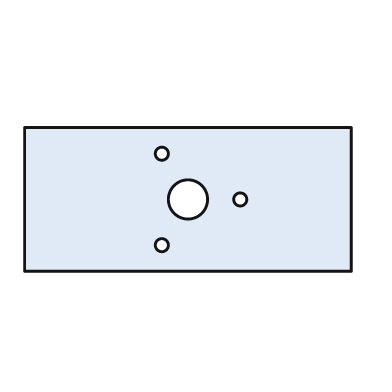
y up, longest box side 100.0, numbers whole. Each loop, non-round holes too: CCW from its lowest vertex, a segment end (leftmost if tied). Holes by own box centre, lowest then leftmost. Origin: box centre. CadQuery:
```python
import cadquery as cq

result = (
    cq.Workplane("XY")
    .moveTo(-50.0, -22.0)
    .lineTo(50.0, -22.0)
    .lineTo(50.0, 22.0)
    .lineTo(-50.0, 22.0)
    .close()
    .moveTo(-8.0, -14.0)
    .circle(2.0)
    .moveTo(0.0, 0.0)
    .circle(6.0)
    .moveTo(16.0, 0.0)
    .circle(2.0)
    .moveTo(-8.0, 14.0)
    .circle(2.0)
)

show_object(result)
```